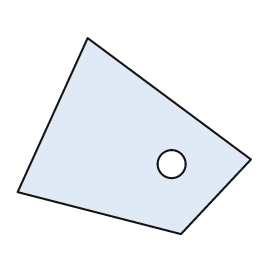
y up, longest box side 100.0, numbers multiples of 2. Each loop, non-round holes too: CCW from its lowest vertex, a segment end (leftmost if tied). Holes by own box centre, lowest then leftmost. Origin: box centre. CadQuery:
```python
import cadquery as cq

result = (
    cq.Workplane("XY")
    .moveTo(20.0, -42.0)
    .lineTo(50.0, -10.0)
    .lineTo(-20.0, 42.0)
    .lineTo(-50.0, -24.0)
    .close()
    .moveTo(16.0, -12.0)
    .circle(6.0)
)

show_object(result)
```